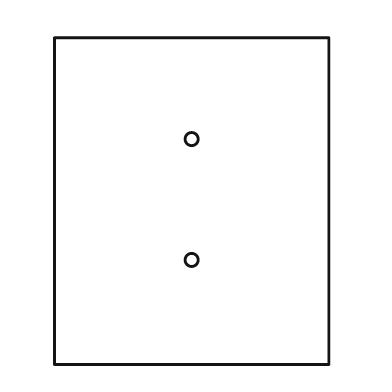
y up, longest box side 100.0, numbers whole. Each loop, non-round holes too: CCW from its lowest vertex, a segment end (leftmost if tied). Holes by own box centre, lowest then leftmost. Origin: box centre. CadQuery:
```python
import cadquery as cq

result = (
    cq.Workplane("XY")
    .moveTo(-42.0, -50.0)
    .lineTo(42.0, -50.0)
    .lineTo(42.0, 50.0)
    .lineTo(-42.0, 50.0)
    .close()
    .moveTo(0.0, -18.0)
    .circle(2.0)
    .moveTo(0.0, 19.0)
    .circle(2.0)
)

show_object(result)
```